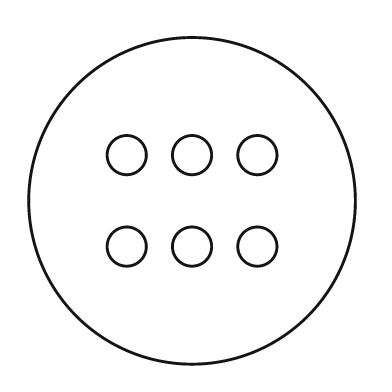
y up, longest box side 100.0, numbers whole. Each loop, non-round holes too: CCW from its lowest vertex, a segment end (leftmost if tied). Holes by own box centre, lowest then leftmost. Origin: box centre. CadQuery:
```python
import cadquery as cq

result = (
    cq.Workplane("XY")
    .moveTo(0.0, 0.0)
    .circle(50.0)
    .moveTo(-20.0, -14.0)
    .circle(6.0)
    .moveTo(0.0, -14.0)
    .circle(6.0)
    .moveTo(20.0, -14.0)
    .circle(6.0)
    .moveTo(-20.0, 14.0)
    .circle(6.0)
    .moveTo(0.0, 14.0)
    .circle(6.0)
    .moveTo(20.0, 14.0)
    .circle(6.0)
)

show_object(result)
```